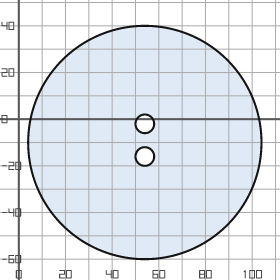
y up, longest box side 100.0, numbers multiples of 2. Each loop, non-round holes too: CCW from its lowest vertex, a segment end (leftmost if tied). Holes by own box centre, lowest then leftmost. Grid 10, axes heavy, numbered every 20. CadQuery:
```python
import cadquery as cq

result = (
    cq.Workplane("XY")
    .moveTo(54.0, -10.0)
    .circle(50.0)
    .moveTo(54.0, -16.0)
    .circle(4.0)
    .moveTo(54.0, -2.0)
    .circle(4.0)
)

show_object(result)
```